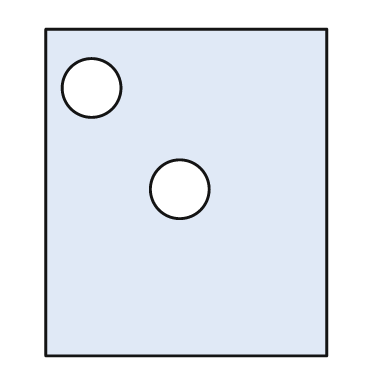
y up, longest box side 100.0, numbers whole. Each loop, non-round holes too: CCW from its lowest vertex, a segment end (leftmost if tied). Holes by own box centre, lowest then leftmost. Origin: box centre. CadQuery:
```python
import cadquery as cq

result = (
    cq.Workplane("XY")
    .moveTo(-43.0, -50.0)
    .lineTo(43.0, -50.0)
    .lineTo(43.0, 50.0)
    .lineTo(-43.0, 50.0)
    .close()
    .moveTo(-2.0, 1.0)
    .circle(9.0)
    .moveTo(-29.0, 32.0)
    .circle(9.0)
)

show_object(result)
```